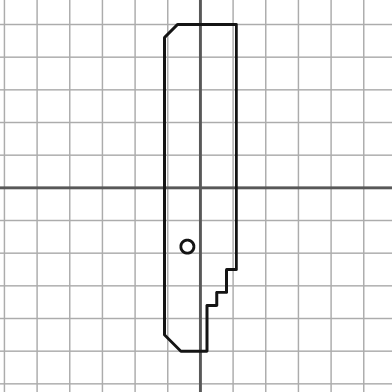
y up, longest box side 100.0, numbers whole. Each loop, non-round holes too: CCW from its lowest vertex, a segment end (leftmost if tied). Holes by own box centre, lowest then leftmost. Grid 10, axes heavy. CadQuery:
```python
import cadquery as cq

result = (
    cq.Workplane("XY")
    .moveTo(-6.0, -50.0)
    .lineTo(2.0, -50.0)
    .lineTo(2.0, -36.0)
    .lineTo(5.0, -36.0)
    .lineTo(5.0, -32.0)
    .lineTo(8.0, -32.0)
    .lineTo(8.0, -25.0)
    .lineTo(11.0, -25.0)
    .lineTo(11.0, 50.0)
    .lineTo(-7.0, 50.0)
    .lineTo(-11.0, 46.0)
    .lineTo(-11.0, -45.0)
    .close()
    .moveTo(-4.0, -18.0)
    .circle(2.0)
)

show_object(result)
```